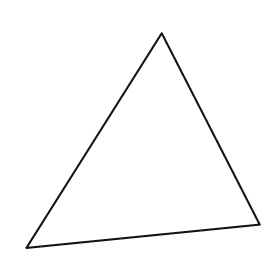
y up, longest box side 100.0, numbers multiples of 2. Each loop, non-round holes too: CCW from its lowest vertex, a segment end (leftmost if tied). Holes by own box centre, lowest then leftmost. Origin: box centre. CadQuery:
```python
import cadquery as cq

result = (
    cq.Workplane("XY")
    .moveTo(-50.0, -46.0)
    .lineTo(50.0, -36.0)
    .lineTo(8.0, 46.0)
    .close()
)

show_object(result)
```